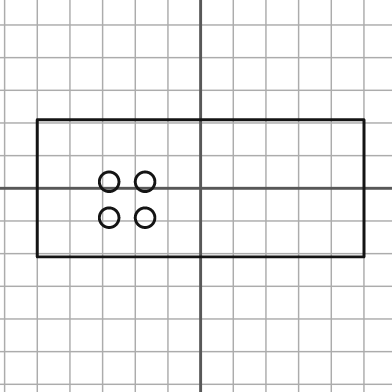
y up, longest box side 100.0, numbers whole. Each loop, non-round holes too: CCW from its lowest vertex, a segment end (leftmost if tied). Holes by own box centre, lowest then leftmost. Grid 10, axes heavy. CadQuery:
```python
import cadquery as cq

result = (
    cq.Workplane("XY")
    .moveTo(-50.0, -21.0)
    .lineTo(50.0, -21.0)
    .lineTo(50.0, 21.0)
    .lineTo(-50.0, 21.0)
    .close()
    .moveTo(-28.0, -9.0)
    .circle(3.0)
    .moveTo(-17.0, -9.0)
    .circle(3.0)
    .moveTo(-28.0, 2.0)
    .circle(3.0)
    .moveTo(-17.0, 2.0)
    .circle(3.0)
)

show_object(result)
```